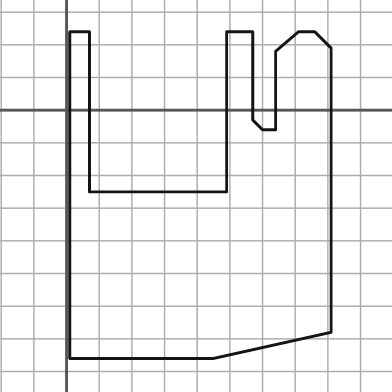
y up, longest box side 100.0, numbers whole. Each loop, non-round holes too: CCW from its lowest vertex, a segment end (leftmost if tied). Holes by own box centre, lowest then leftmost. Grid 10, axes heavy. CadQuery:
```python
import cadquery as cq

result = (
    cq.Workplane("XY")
    .moveTo(1.0, -76.0)
    .lineTo(45.0, -76.0)
    .lineTo(81.0, -68.0)
    .lineTo(81.0, 19.0)
    .lineTo(76.0, 24.0)
    .lineTo(71.0, 24.0)
    .lineTo(64.0, 18.0)
    .lineTo(64.0, -6.0)
    .lineTo(60.0, -6.0)
    .lineTo(57.0, -3.0)
    .lineTo(57.0, 24.0)
    .lineTo(49.0, 24.0)
    .lineTo(49.0, -25.0)
    .lineTo(7.0, -25.0)
    .lineTo(7.0, 24.0)
    .lineTo(1.0, 24.0)
    .close()
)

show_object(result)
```